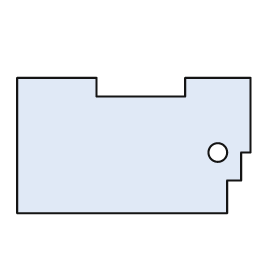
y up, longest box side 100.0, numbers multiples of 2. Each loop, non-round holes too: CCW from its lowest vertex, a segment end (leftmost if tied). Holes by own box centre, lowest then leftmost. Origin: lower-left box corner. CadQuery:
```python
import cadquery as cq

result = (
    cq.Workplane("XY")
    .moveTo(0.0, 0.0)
    .lineTo(90.0, 0.0)
    .lineTo(90.0, 14.0)
    .lineTo(96.0, 14.0)
    .lineTo(96.0, 26.0)
    .lineTo(100.0, 26.0)
    .lineTo(100.0, 58.0)
    .lineTo(72.0, 58.0)
    .lineTo(72.0, 50.0)
    .lineTo(34.0, 50.0)
    .lineTo(34.0, 58.0)
    .lineTo(0.0, 58.0)
    .close()
    .moveTo(86.0, 26.0)
    .circle(4.0)
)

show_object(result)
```